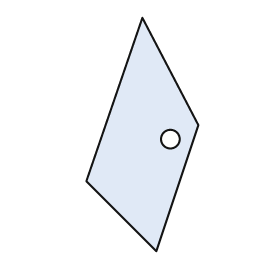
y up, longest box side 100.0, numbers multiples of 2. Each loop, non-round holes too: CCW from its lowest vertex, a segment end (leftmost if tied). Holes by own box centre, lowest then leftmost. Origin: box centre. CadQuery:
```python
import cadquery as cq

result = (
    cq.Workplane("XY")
    .moveTo(6.0, -50.0)
    .lineTo(24.0, 4.0)
    .lineTo(0.0, 50.0)
    .lineTo(-24.0, -20.0)
    .close()
    .moveTo(12.0, -2.0)
    .circle(4.0)
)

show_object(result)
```